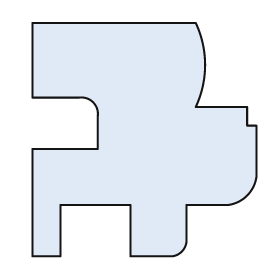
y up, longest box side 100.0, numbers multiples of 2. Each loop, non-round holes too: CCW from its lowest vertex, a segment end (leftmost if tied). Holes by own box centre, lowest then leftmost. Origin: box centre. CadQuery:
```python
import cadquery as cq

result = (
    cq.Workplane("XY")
    .moveTo(-48.0, -50.0)
    .lineTo(-36.0, -50.0)
    .lineTo(-36.0, -28.0)
    .lineTo(-6.0, -28.0)
    .lineTo(-6.0, -50.0)
    .lineTo(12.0, -50.0)
    .threePointArc((16.0, -48.0), (18.0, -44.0))
    .lineTo(18.0, -28.0)
    .lineTo(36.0, -28.0)
    .threePointArc((44.0, -24.0), (48.0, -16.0))
    .lineTo(48.0, 6.0)
    .lineTo(44.0, 6.0)
    .lineTo(44.0, 14.0)
    .lineTo(22.0, 14.0)
    .threePointArc((26.0, 32.0), (22.0, 50.0))
    .lineTo(-48.0, 50.0)
    .lineTo(-48.0, 18.0)
    .lineTo(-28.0, 18.0)
    .threePointArc((-22.0, 16.0), (-20.0, 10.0))
    .lineTo(-20.0, -4.0)
    .lineTo(-48.0, -4.0)
    .close()
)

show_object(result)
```